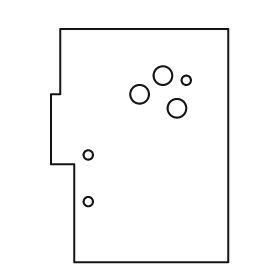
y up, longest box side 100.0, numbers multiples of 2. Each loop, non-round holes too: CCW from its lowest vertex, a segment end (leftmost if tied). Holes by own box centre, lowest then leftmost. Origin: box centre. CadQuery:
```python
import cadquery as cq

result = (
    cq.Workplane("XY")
    .moveTo(-28.0, -50.0)
    .lineTo(38.0, -50.0)
    .lineTo(38.0, 50.0)
    .lineTo(-34.0, 50.0)
    .lineTo(-34.0, 22.0)
    .lineTo(-38.0, 22.0)
    .lineTo(-38.0, -8.0)
    .lineTo(-28.0, -8.0)
    .close()
    .moveTo(-22.0, -24.0)
    .circle(2.0)
    .moveTo(-22.0, -4.0)
    .circle(2.0)
    .moveTo(16.0, 16.0)
    .circle(4.0)
    .moveTo(0.0, 22.0)
    .circle(4.0)
    .moveTo(20.0, 28.0)
    .circle(2.0)
    .moveTo(10.0, 30.0)
    .circle(4.0)
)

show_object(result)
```